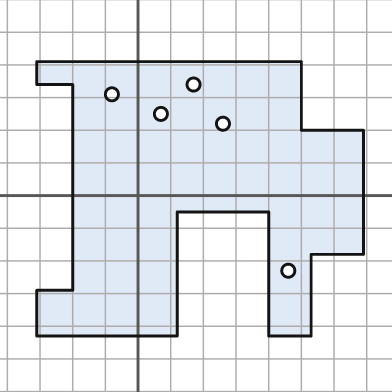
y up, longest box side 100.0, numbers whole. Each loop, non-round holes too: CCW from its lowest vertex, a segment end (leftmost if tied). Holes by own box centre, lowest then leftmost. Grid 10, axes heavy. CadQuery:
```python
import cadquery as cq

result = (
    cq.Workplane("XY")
    .moveTo(-31.0, -43.0)
    .lineTo(12.0, -43.0)
    .lineTo(12.0, -5.0)
    .lineTo(40.0, -5.0)
    .lineTo(40.0, -43.0)
    .lineTo(53.0, -43.0)
    .lineTo(53.0, -18.0)
    .lineTo(69.0, -18.0)
    .lineTo(69.0, 20.0)
    .lineTo(50.0, 20.0)
    .lineTo(50.0, 41.0)
    .lineTo(-31.0, 41.0)
    .lineTo(-31.0, 34.0)
    .lineTo(-20.0, 34.0)
    .lineTo(-20.0, -29.0)
    .lineTo(-31.0, -29.0)
    .close()
    .moveTo(46.0, -23.0)
    .circle(2.0)
    .moveTo(26.0, 22.0)
    .circle(2.0)
    .moveTo(7.0, 25.0)
    .circle(2.0)
    .moveTo(-8.0, 31.0)
    .circle(2.0)
    .moveTo(17.0, 34.0)
    .circle(2.0)
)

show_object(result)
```